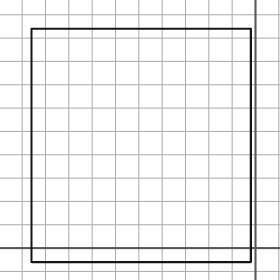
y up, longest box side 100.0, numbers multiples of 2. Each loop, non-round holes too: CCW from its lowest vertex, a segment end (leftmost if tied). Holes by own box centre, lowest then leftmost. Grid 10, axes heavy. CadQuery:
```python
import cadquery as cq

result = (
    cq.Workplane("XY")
    .moveTo(-96.0, -6.0)
    .lineTo(-2.0, -6.0)
    .lineTo(-2.0, 94.0)
    .lineTo(-96.0, 94.0)
    .close()
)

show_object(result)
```